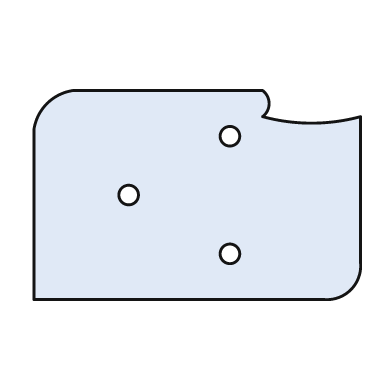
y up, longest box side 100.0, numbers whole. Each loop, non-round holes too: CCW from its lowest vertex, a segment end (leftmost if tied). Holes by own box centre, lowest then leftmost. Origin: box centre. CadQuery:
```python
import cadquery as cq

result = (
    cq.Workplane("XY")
    .moveTo(-50.0, -32.0)
    .lineTo(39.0, -32.0)
    .threePointArc((47.0, -29.0), (50.0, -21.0))
    .lineTo(50.0, 24.0)
    .threePointArc((35.0, 22.0), (20.0, 24.0))
    .threePointArc((22.0, 28.0), (20.0, 32.0))
    .lineTo(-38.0, 32.0)
    .threePointArc((-46.0, 28.0), (-50.0, 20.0))
    .close()
    .moveTo(10.0, -18.0)
    .circle(3.0)
    .moveTo(-21.0, 0.0)
    .circle(3.0)
    .moveTo(10.0, 18.0)
    .circle(3.0)
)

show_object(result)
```